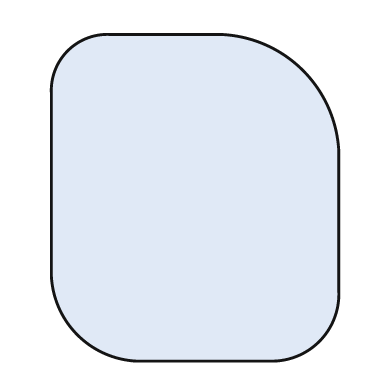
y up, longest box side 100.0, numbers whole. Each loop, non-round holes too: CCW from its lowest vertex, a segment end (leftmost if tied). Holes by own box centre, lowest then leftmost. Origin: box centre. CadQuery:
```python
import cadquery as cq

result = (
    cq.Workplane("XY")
    .moveTo(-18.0, -50.0)
    .lineTo(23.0, -50.0)
    .threePointArc((38.0, -44.0), (44.0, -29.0))
    .lineTo(44.0, 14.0)
    .threePointArc((33.0, 39.0), (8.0, 50.0))
    .lineTo(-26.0, 50.0)
    .threePointArc((-39.0, 45.0), (-44.0, 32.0))
    .lineTo(-44.0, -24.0)
    .threePointArc((-36.0, -42.0), (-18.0, -50.0))
    .close()
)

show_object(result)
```